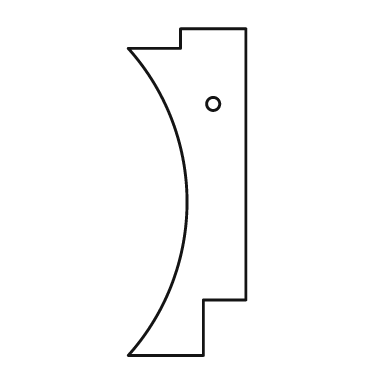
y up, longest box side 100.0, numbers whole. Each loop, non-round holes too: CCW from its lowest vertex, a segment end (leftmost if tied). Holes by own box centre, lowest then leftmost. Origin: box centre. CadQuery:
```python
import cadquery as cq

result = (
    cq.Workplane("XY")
    .moveTo(-18.0, -50.0)
    .lineTo(5.0, -50.0)
    .lineTo(5.0, -33.0)
    .lineTo(18.0, -33.0)
    .lineTo(18.0, 50.0)
    .lineTo(-2.0, 50.0)
    .lineTo(-2.0, 44.0)
    .lineTo(-18.0, 44.0)
    .threePointArc((0.0, -3.0), (-18.0, -50.0))
    .close()
    .moveTo(8.0, 27.0)
    .circle(2.0)
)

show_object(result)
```